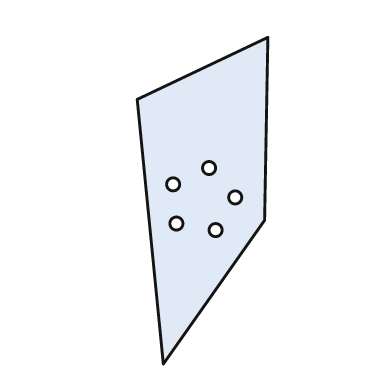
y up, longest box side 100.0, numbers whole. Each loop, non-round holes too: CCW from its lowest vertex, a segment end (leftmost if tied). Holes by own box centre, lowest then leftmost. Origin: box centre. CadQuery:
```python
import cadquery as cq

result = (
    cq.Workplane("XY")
    .moveTo(-12.0, -50.0)
    .lineTo(19.0, -6.0)
    .lineTo(20.0, 50.0)
    .lineTo(-20.0, 31.0)
    .close()
    .moveTo(4.0, -9.0)
    .circle(2.0)
    .moveTo(-8.0, -7.0)
    .circle(2.0)
    .moveTo(10.0, 1.0)
    .circle(2.0)
    .moveTo(-9.0, 5.0)
    .circle(2.0)
    .moveTo(2.0, 10.0)
    .circle(2.0)
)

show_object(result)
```